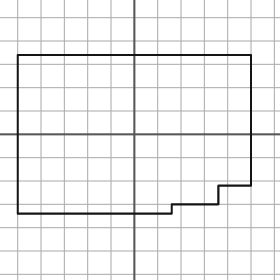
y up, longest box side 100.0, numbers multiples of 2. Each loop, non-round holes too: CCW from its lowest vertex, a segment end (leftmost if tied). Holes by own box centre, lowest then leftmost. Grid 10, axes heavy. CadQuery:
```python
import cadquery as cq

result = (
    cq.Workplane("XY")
    .moveTo(-50.0, -34.0)
    .lineTo(16.0, -34.0)
    .lineTo(16.0, -30.0)
    .lineTo(36.0, -30.0)
    .lineTo(36.0, -22.0)
    .lineTo(50.0, -22.0)
    .lineTo(50.0, 34.0)
    .lineTo(-50.0, 34.0)
    .close()
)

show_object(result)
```